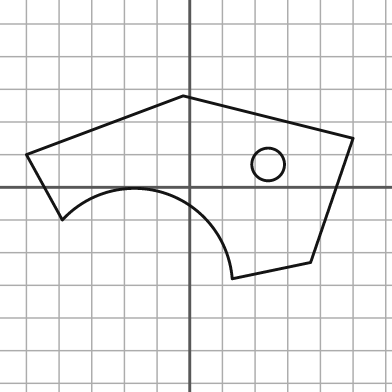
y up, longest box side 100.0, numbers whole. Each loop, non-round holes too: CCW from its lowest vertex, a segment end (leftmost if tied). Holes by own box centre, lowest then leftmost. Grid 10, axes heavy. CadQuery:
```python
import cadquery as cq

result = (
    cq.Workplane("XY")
    .moveTo(13.0, -28.0)
    .lineTo(37.0, -23.0)
    .lineTo(50.0, 15.0)
    .lineTo(-2.0, 28.0)
    .lineTo(-50.0, 10.0)
    .lineTo(-39.0, -10.0)
    .threePointArc((-7.0, -2.0), (13.0, -28.0))
    .close()
    .moveTo(24.0, 7.0)
    .circle(5.0)
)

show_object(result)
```